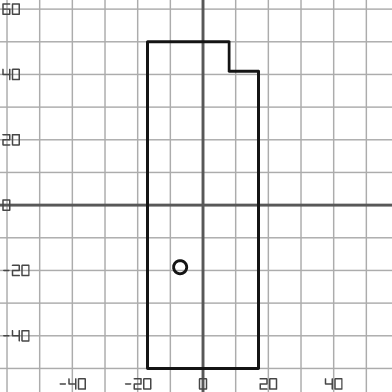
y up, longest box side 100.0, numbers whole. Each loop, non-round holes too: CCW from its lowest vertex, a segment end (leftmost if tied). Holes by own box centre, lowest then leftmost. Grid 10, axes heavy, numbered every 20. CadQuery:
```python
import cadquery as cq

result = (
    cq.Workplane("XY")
    .moveTo(-17.0, -50.0)
    .lineTo(17.0, -50.0)
    .lineTo(17.0, 41.0)
    .lineTo(8.0, 41.0)
    .lineTo(8.0, 50.0)
    .lineTo(-17.0, 50.0)
    .close()
    .moveTo(-7.0, -19.0)
    .circle(2.0)
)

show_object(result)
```